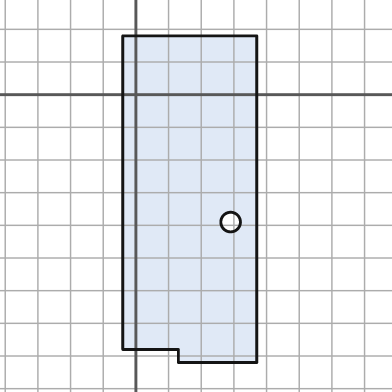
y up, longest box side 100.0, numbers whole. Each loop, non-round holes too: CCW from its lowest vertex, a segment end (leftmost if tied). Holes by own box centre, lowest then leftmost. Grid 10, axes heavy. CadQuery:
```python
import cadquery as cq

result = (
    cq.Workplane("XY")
    .moveTo(13.0, -82.0)
    .lineTo(37.0, -82.0)
    .lineTo(37.0, 18.0)
    .lineTo(-4.0, 18.0)
    .lineTo(-4.0, -78.0)
    .lineTo(13.0, -78.0)
    .close()
    .moveTo(29.0, -39.0)
    .circle(3.0)
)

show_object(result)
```